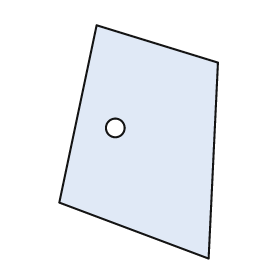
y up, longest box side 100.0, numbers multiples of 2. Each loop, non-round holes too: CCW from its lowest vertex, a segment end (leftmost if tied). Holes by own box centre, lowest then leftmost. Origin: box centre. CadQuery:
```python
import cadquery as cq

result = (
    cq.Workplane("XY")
    .moveTo(30.0, -50.0)
    .lineTo(34.0, 34.0)
    .lineTo(-18.0, 50.0)
    .lineTo(-34.0, -26.0)
    .close()
    .moveTo(-10.0, 6.0)
    .circle(4.0)
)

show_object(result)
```